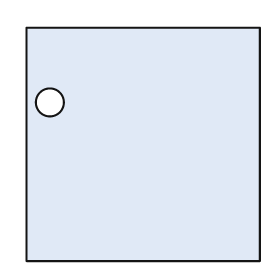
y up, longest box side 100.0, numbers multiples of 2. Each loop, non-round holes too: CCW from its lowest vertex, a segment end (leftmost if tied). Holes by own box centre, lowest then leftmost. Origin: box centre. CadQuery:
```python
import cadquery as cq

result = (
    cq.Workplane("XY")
    .moveTo(-50.0, -50.0)
    .lineTo(50.0, -50.0)
    .lineTo(50.0, 50.0)
    .lineTo(-50.0, 50.0)
    .close()
    .moveTo(-40.0, 18.0)
    .circle(6.0)
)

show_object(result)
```